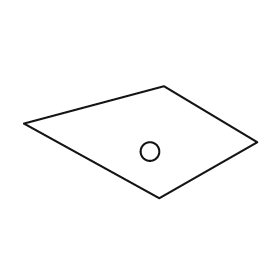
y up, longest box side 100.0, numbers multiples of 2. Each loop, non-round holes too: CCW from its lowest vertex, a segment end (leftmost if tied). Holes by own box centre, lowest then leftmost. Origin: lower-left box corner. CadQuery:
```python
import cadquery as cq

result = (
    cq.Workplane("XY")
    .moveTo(58.0, 0.0)
    .lineTo(100.0, 24.0)
    .lineTo(60.0, 48.0)
    .lineTo(0.0, 32.0)
    .close()
    .moveTo(54.0, 20.0)
    .circle(4.0)
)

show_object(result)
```